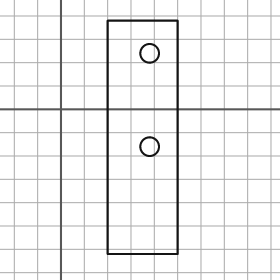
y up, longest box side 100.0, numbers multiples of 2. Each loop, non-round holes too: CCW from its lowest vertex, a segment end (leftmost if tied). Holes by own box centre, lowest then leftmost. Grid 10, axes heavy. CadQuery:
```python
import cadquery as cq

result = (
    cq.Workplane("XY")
    .moveTo(20.0, -62.0)
    .lineTo(50.0, -62.0)
    .lineTo(50.0, 38.0)
    .lineTo(20.0, 38.0)
    .close()
    .moveTo(38.0, -16.0)
    .circle(4.0)
    .moveTo(38.0, 24.0)
    .circle(4.0)
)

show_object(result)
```